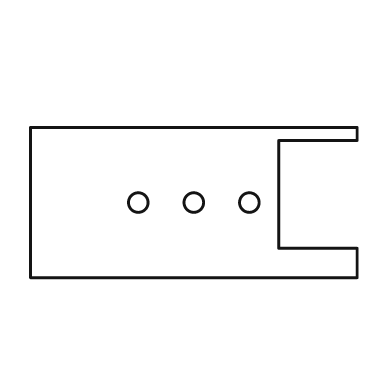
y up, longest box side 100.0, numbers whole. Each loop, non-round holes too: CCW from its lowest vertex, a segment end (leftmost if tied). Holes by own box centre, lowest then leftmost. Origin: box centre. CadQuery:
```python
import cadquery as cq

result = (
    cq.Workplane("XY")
    .moveTo(-50.0, -23.0)
    .lineTo(50.0, -23.0)
    .lineTo(50.0, -14.0)
    .lineTo(26.0, -14.0)
    .lineTo(26.0, 19.0)
    .lineTo(50.0, 19.0)
    .lineTo(50.0, 23.0)
    .lineTo(-50.0, 23.0)
    .close()
    .moveTo(-17.0, 0.0)
    .circle(3.0)
    .moveTo(0.0, 0.0)
    .circle(3.0)
    .moveTo(17.0, 0.0)
    .circle(3.0)
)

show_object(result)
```